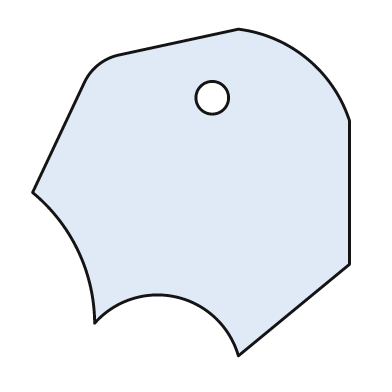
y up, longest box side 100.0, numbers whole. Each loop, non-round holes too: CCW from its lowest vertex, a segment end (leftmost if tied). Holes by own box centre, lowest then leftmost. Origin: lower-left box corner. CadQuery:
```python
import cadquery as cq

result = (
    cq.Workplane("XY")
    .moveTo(63.0, 0.0)
    .lineTo(97.0, 28.0)
    .lineTo(97.0, 72.0)
    .threePointArc((84.0, 91.0), (63.0, 100.0))
    .lineTo(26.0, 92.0)
    .threePointArc((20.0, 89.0), (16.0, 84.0))
    .lineTo(0.0, 50.0)
    .threePointArc((14.0, 32.0), (19.0, 10.0))
    .threePointArc((44.0, 18.0), (63.0, 0.0))
    .close()
    .moveTo(55.0, 79.0)
    .circle(5.0)
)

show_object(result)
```